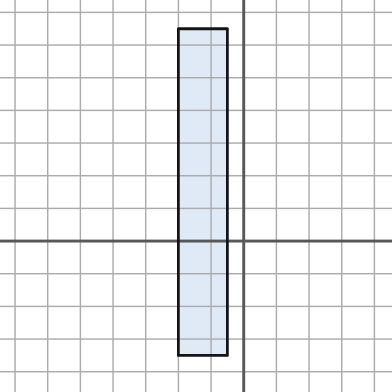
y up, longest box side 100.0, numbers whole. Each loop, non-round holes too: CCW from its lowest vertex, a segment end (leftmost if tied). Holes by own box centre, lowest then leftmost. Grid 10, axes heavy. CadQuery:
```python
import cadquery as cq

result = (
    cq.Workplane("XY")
    .moveTo(-20.0, -35.0)
    .lineTo(-5.0, -35.0)
    .lineTo(-5.0, 65.0)
    .lineTo(-20.0, 65.0)
    .close()
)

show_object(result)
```